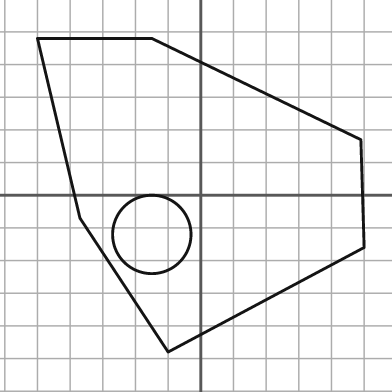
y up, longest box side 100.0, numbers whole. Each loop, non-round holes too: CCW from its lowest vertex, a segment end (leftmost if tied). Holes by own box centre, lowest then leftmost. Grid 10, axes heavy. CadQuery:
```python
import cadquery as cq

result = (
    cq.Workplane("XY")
    .moveTo(-10.0, -48.0)
    .lineTo(50.0, -16.0)
    .lineTo(49.0, 17.0)
    .lineTo(-15.0, 48.0)
    .lineTo(-50.0, 48.0)
    .lineTo(-37.0, -7.0)
    .close()
    .moveTo(-15.0, -12.0)
    .circle(12.0)
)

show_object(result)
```